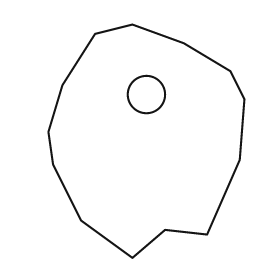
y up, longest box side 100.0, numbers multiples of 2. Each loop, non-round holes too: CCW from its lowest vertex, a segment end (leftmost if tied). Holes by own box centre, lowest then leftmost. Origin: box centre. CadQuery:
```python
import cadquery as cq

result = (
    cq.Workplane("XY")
    .moveTo(-6.0, -50.0)
    .lineTo(8.0, -38.0)
    .lineTo(26.0, -40.0)
    .lineTo(40.0, -8.0)
    .lineTo(42.0, 18.0)
    .lineTo(36.0, 30.0)
    .lineTo(16.0, 42.0)
    .lineTo(-6.0, 50.0)
    .lineTo(-22.0, 46.0)
    .lineTo(-36.0, 24.0)
    .lineTo(-42.0, 4.0)
    .lineTo(-40.0, -10.0)
    .lineTo(-28.0, -34.0)
    .close()
    .moveTo(0.0, 20.0)
    .circle(8.0)
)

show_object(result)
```